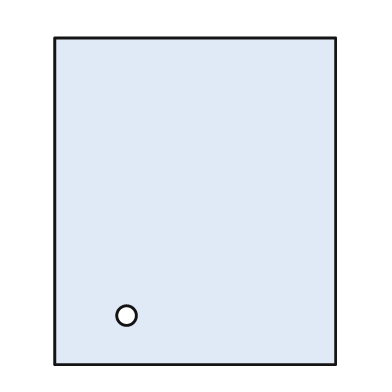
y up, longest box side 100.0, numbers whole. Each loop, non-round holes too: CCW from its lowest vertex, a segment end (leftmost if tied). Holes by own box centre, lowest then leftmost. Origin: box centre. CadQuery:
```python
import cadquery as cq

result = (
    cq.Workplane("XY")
    .moveTo(-43.0, -50.0)
    .lineTo(43.0, -50.0)
    .lineTo(43.0, 50.0)
    .lineTo(-43.0, 50.0)
    .close()
    .moveTo(-21.0, -35.0)
    .circle(3.0)
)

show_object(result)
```